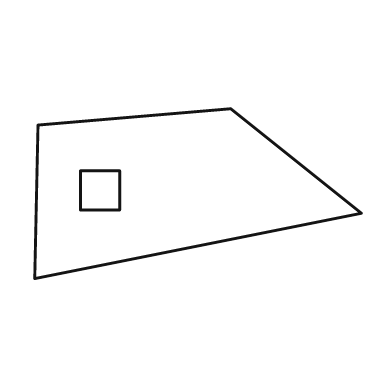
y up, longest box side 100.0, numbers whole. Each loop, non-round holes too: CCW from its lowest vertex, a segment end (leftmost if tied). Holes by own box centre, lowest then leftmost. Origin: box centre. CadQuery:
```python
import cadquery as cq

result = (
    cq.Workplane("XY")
    .moveTo(-50.0, -26.0)
    .lineTo(50.0, -6.0)
    .lineTo(10.0, 26.0)
    .lineTo(-49.0, 21.0)
    .close()
    .moveTo(-36.0, -5.0)
    .lineTo(-24.0, -5.0)
    .lineTo(-24.0, 7.0)
    .lineTo(-36.0, 7.0)
    .close()
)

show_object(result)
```